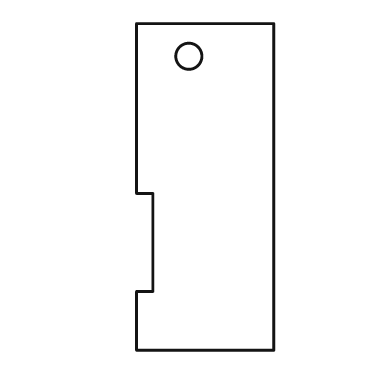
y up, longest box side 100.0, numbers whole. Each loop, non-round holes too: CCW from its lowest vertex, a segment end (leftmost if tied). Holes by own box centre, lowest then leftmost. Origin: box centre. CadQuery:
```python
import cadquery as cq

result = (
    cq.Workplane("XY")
    .moveTo(-21.0, -50.0)
    .lineTo(21.0, -50.0)
    .lineTo(21.0, 50.0)
    .lineTo(-21.0, 50.0)
    .lineTo(-21.0, -2.0)
    .lineTo(-16.0, -2.0)
    .lineTo(-16.0, -32.0)
    .lineTo(-21.0, -32.0)
    .close()
    .moveTo(-5.0, 40.0)
    .circle(4.0)
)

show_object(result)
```